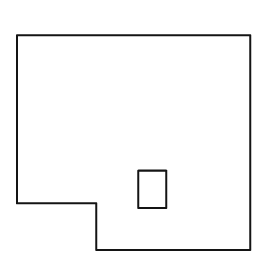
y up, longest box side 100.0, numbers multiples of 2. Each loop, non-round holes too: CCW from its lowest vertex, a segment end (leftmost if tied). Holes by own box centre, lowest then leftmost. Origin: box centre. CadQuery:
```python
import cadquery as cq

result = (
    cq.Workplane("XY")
    .moveTo(-16.0, -46.0)
    .lineTo(50.0, -46.0)
    .lineTo(50.0, 46.0)
    .lineTo(-50.0, 46.0)
    .lineTo(-50.0, -26.0)
    .lineTo(-16.0, -26.0)
    .close()
    .moveTo(2.0, -28.0)
    .lineTo(14.0, -28.0)
    .lineTo(14.0, -12.0)
    .lineTo(2.0, -12.0)
    .close()
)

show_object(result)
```